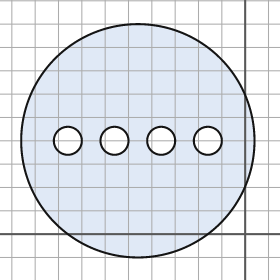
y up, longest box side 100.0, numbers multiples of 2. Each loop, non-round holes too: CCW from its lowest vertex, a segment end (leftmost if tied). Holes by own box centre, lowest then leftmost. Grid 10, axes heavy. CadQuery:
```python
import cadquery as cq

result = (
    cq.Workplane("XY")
    .moveTo(-46.0, 40.0)
    .circle(50.0)
    .moveTo(-76.0, 40.0)
    .circle(6.0)
    .moveTo(-56.0, 40.0)
    .circle(6.0)
    .moveTo(-36.0, 40.0)
    .circle(6.0)
    .moveTo(-16.0, 40.0)
    .circle(6.0)
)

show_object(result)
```